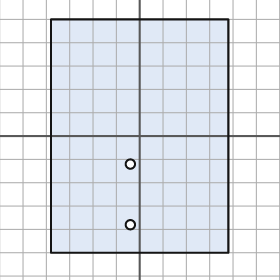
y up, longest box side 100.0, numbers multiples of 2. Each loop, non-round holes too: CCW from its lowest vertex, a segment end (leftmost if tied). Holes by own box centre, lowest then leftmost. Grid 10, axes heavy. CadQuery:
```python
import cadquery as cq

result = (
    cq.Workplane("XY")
    .moveTo(-38.0, -50.0)
    .lineTo(38.0, -50.0)
    .lineTo(38.0, 50.0)
    .lineTo(-38.0, 50.0)
    .close()
    .moveTo(-4.0, -38.0)
    .circle(2.0)
    .moveTo(-4.0, -12.0)
    .circle(2.0)
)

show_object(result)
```